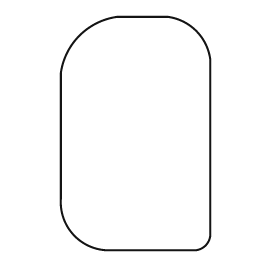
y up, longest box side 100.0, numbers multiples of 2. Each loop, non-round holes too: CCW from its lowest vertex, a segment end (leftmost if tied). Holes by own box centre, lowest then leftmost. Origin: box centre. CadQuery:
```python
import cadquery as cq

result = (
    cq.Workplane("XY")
    .moveTo(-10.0, -50.0)
    .lineTo(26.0, -50.0)
    .threePointArc((30.0, -48.0), (32.0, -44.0))
    .lineTo(32.0, 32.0)
    .threePointArc((26.0, 44.0), (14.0, 50.0))
    .lineTo(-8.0, 50.0)
    .threePointArc((-24.0, 42.0), (-32.0, 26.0))
    .lineTo(-32.0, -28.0)
    .threePointArc((-26.0, -44.0), (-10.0, -50.0))
    .close()
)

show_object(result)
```